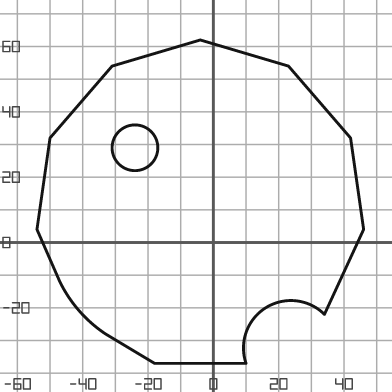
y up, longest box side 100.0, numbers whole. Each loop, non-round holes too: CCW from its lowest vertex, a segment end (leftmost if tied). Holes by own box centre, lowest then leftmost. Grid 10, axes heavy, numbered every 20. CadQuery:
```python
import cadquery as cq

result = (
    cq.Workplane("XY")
    .moveTo(-18.0, -37.0)
    .lineTo(10.0, -37.0)
    .threePointArc((16.0, -20.0), (34.0, -22.0))
    .lineTo(46.0, 4.0)
    .lineTo(42.0, 32.0)
    .lineTo(23.0, 54.0)
    .lineTo(-4.0, 62.0)
    .lineTo(-31.0, 54.0)
    .lineTo(-50.0, 32.0)
    .lineTo(-54.0, 4.0)
    .lineTo(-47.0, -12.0)
    .threePointArc((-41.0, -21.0), (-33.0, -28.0))
    .close()
    .moveTo(-24.0, 29.0)
    .circle(7.0)
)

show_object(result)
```